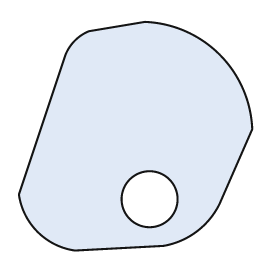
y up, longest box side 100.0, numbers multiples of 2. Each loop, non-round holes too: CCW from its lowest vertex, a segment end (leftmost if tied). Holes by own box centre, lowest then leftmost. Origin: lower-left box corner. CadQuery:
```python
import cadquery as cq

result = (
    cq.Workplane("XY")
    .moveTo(24.0, 0.0)
    .lineTo(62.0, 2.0)
    .threePointArc((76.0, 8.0), (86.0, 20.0))
    .lineTo(100.0, 52.0)
    .threePointArc((86.0, 84.0), (54.0, 98.0))
    .lineTo(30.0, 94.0)
    .threePointArc((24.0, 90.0), (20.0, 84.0))
    .lineTo(0.0, 24.0)
    .threePointArc((8.0, 8.0), (24.0, 0.0))
    .close()
    .moveTo(56.0, 22.0)
    .circle(12.0)
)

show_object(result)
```